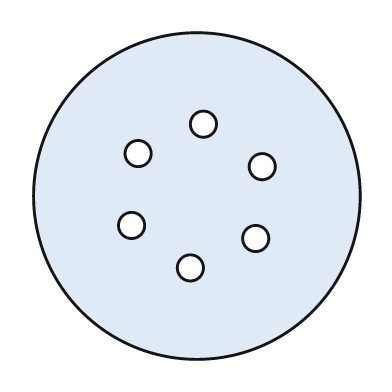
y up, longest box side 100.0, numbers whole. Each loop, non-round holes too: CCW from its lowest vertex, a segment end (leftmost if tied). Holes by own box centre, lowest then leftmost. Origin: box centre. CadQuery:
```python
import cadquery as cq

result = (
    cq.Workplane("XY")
    .moveTo(0.0, 0.0)
    .circle(50.0)
    .moveTo(-2.0, -22.0)
    .circle(4.0)
    .moveTo(18.0, -13.0)
    .circle(4.0)
    .moveTo(-20.0, -9.0)
    .circle(4.0)
    .moveTo(20.0, 9.0)
    .circle(4.0)
    .moveTo(-18.0, 13.0)
    .circle(4.0)
    .moveTo(2.0, 22.0)
    .circle(4.0)
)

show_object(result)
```